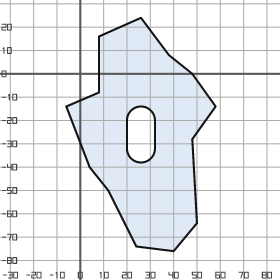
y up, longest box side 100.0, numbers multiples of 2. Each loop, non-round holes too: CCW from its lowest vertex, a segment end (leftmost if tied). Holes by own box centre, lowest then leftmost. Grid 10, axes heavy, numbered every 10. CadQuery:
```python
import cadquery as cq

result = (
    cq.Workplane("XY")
    .moveTo(40.0, -76.0)
    .lineTo(50.0, -64.0)
    .lineTo(48.0, -28.0)
    .lineTo(58.0, -14.0)
    .lineTo(48.0, 0.0)
    .lineTo(38.0, 8.0)
    .lineTo(26.0, 24.0)
    .lineTo(8.0, 16.0)
    .lineTo(8.0, -8.0)
    .lineTo(-6.0, -14.0)
    .lineTo(4.0, -40.0)
    .lineTo(12.0, -50.0)
    .lineTo(24.0, -74.0)
    .close()
    .moveTo(20.0, -32.0)
    .threePointArc((26.0, -38.0), (32.0, -32.0))
    .lineTo(32.0, -20.0)
    .threePointArc((26.0, -14.0), (20.0, -20.0))
    .close()
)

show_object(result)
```